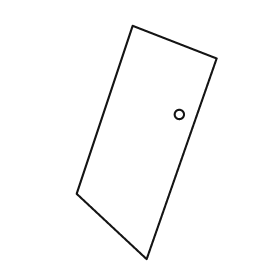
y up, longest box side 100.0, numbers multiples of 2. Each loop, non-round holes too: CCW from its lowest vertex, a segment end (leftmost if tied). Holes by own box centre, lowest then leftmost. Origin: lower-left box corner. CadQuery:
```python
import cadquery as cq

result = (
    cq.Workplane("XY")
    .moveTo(30.0, 0.0)
    .lineTo(60.0, 86.0)
    .lineTo(24.0, 100.0)
    .lineTo(0.0, 28.0)
    .close()
    .moveTo(44.0, 62.0)
    .circle(2.0)
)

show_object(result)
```